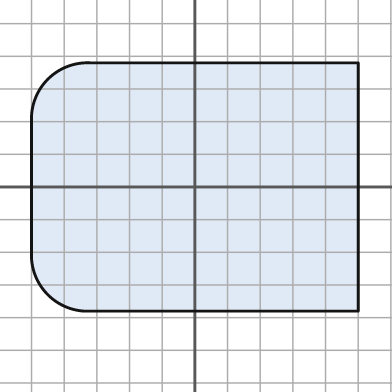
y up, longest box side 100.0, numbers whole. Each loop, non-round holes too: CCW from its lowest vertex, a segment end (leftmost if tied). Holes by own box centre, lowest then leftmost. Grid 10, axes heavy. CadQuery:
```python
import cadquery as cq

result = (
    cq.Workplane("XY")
    .moveTo(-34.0, -38.0)
    .lineTo(50.0, -38.0)
    .lineTo(50.0, 38.0)
    .lineTo(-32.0, 38.0)
    .threePointArc((-45.0, 33.0), (-50.0, 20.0))
    .lineTo(-50.0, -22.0)
    .threePointArc((-45.0, -33.0), (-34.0, -38.0))
    .close()
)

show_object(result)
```